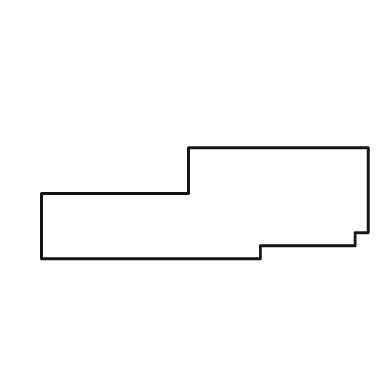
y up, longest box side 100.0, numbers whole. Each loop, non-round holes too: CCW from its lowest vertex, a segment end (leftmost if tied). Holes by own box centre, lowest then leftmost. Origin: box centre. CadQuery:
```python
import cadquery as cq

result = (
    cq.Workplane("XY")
    .moveTo(-50.0, -17.0)
    .lineTo(17.0, -17.0)
    .lineTo(17.0, -13.0)
    .lineTo(46.0, -13.0)
    .lineTo(46.0, -9.0)
    .lineTo(50.0, -9.0)
    .lineTo(50.0, 17.0)
    .lineTo(-5.0, 17.0)
    .lineTo(-5.0, 3.0)
    .lineTo(-50.0, 3.0)
    .close()
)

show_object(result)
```